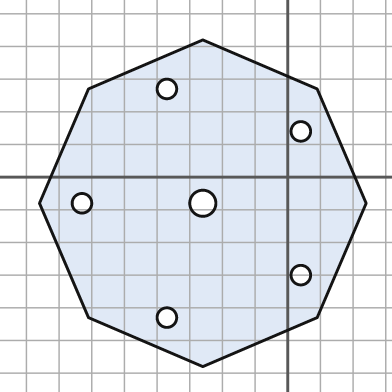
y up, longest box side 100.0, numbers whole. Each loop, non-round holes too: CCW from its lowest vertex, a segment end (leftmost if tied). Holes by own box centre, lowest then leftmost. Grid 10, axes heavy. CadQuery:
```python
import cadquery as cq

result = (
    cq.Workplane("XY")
    .moveTo(-26.0, -58.0)
    .lineTo(9.0, -43.0)
    .lineTo(24.0, -8.0)
    .lineTo(9.0, 27.0)
    .lineTo(-26.0, 42.0)
    .lineTo(-61.0, 27.0)
    .lineTo(-76.0, -8.0)
    .lineTo(-61.0, -43.0)
    .close()
    .moveTo(-37.0, -43.0)
    .circle(3.0)
    .moveTo(4.0, -30.0)
    .circle(3.0)
    .moveTo(-63.0, -8.0)
    .circle(3.0)
    .moveTo(-26.0, -8.0)
    .circle(4.0)
    .moveTo(4.0, 14.0)
    .circle(3.0)
    .moveTo(-37.0, 27.0)
    .circle(3.0)
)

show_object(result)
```